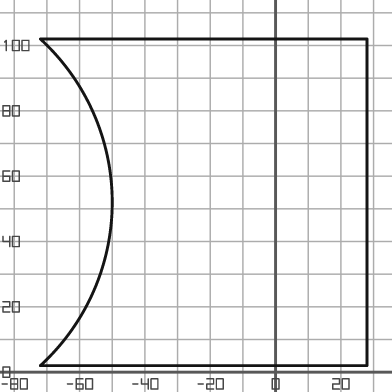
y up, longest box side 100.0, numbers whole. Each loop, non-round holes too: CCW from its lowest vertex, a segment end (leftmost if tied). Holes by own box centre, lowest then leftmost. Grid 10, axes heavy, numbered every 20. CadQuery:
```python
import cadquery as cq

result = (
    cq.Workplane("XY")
    .moveTo(-72.0, 2.0)
    .lineTo(28.0, 2.0)
    .lineTo(28.0, 102.0)
    .lineTo(-72.0, 102.0)
    .threePointArc((-50.0, 52.0), (-72.0, 2.0))
    .close()
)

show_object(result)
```